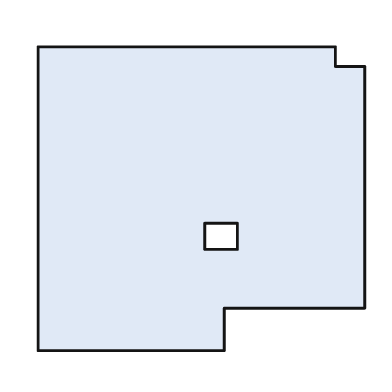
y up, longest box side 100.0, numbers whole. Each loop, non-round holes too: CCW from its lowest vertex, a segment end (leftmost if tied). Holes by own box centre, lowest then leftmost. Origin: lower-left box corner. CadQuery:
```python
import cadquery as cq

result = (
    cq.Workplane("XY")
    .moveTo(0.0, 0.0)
    .lineTo(57.0, 0.0)
    .lineTo(57.0, 13.0)
    .lineTo(100.0, 13.0)
    .lineTo(100.0, 87.0)
    .lineTo(91.0, 87.0)
    .lineTo(91.0, 93.0)
    .lineTo(0.0, 93.0)
    .close()
    .moveTo(51.0, 31.0)
    .lineTo(61.0, 31.0)
    .lineTo(61.0, 39.0)
    .lineTo(51.0, 39.0)
    .close()
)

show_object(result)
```